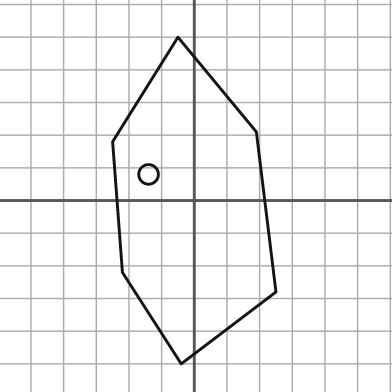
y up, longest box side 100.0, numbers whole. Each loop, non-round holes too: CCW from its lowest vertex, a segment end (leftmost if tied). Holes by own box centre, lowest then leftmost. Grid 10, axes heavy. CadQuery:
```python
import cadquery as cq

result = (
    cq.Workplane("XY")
    .moveTo(-4.0, -50.0)
    .lineTo(25.0, -28.0)
    .lineTo(19.0, 21.0)
    .lineTo(-5.0, 50.0)
    .lineTo(-25.0, 18.0)
    .lineTo(-22.0, -22.0)
    .close()
    .moveTo(-14.0, 8.0)
    .circle(3.0)
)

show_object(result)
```